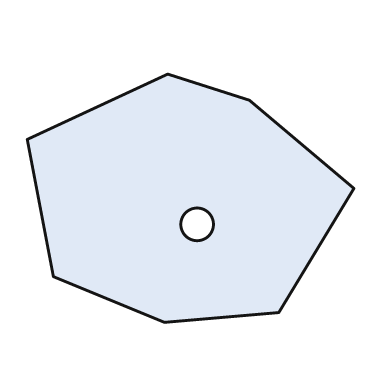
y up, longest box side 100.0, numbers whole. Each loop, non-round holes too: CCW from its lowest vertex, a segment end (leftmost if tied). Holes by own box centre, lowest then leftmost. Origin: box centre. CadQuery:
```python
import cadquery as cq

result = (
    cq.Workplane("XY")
    .moveTo(-8.0, -38.0)
    .lineTo(27.0, -35.0)
    .lineTo(50.0, 3.0)
    .lineTo(18.0, 30.0)
    .lineTo(-7.0, 38.0)
    .lineTo(-50.0, 18.0)
    .lineTo(-42.0, -24.0)
    .close()
    .moveTo(2.0, -8.0)
    .circle(5.0)
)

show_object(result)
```